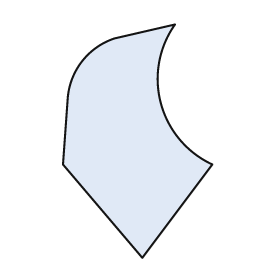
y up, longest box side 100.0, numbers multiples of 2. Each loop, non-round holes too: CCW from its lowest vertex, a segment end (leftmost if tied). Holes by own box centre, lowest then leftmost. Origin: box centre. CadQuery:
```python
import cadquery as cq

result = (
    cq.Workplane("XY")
    .moveTo(2.0, -50.0)
    .lineTo(32.0, -10.0)
    .threePointArc((10.0, 16.0), (16.0, 50.0))
    .lineTo(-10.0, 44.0)
    .threePointArc((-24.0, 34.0), (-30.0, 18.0))
    .lineTo(-32.0, -10.0)
    .close()
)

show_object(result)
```